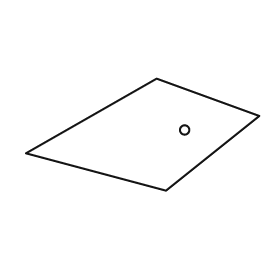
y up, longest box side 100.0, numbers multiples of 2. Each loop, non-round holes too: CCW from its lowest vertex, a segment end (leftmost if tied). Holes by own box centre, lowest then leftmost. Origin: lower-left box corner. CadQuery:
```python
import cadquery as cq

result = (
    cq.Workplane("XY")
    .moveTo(60.0, 0.0)
    .lineTo(100.0, 32.0)
    .lineTo(56.0, 48.0)
    .lineTo(0.0, 16.0)
    .close()
    .moveTo(68.0, 26.0)
    .circle(2.0)
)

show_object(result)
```